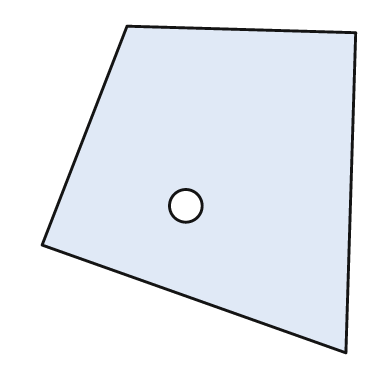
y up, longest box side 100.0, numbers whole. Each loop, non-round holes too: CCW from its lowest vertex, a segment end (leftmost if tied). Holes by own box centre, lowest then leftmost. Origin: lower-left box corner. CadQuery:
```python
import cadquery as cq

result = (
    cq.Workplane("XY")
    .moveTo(93.0, 0.0)
    .lineTo(96.0, 98.0)
    .lineTo(26.0, 100.0)
    .lineTo(0.0, 33.0)
    .close()
    .moveTo(44.0, 45.0)
    .circle(5.0)
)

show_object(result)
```